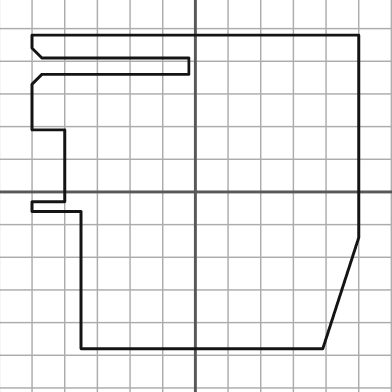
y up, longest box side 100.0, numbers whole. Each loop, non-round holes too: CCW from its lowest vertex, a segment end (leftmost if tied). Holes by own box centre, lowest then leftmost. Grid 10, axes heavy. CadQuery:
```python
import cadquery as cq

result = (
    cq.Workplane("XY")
    .moveTo(-35.0, -48.0)
    .lineTo(39.0, -48.0)
    .lineTo(50.0, -14.0)
    .lineTo(50.0, 48.0)
    .lineTo(-50.0, 48.0)
    .lineTo(-50.0, 44.0)
    .lineTo(-47.0, 41.0)
    .lineTo(-2.0, 41.0)
    .lineTo(-2.0, 36.0)
    .lineTo(-47.0, 36.0)
    .lineTo(-50.0, 33.0)
    .lineTo(-50.0, 19.0)
    .lineTo(-40.0, 19.0)
    .lineTo(-40.0, -3.0)
    .lineTo(-50.0, -3.0)
    .lineTo(-50.0, -6.0)
    .lineTo(-35.0, -6.0)
    .close()
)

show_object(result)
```